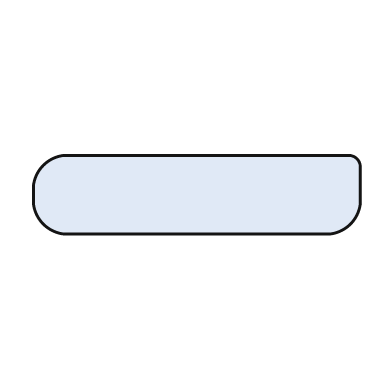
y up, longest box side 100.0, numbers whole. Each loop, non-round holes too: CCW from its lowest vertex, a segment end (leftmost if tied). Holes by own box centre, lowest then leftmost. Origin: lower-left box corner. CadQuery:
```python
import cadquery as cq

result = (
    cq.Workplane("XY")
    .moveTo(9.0, 0.0)
    .lineTo(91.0, 0.0)
    .threePointArc((97.0, 3.0), (100.0, 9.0))
    .lineTo(100.0, 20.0)
    .threePointArc((99.0, 23.0), (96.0, 24.0))
    .lineTo(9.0, 24.0)
    .threePointArc((3.0, 21.0), (0.0, 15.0))
    .lineTo(0.0, 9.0)
    .threePointArc((3.0, 3.0), (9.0, 0.0))
    .close()
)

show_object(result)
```